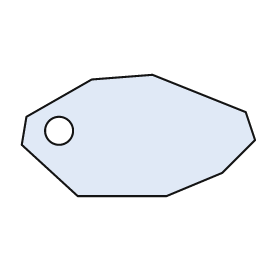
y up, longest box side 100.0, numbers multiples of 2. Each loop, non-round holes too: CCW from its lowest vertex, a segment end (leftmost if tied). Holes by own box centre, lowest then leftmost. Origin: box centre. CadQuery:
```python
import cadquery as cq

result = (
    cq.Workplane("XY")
    .moveTo(-26.0, -26.0)
    .lineTo(12.0, -26.0)
    .lineTo(36.0, -16.0)
    .lineTo(50.0, -2.0)
    .lineTo(46.0, 10.0)
    .lineTo(6.0, 26.0)
    .lineTo(-20.0, 24.0)
    .lineTo(-48.0, 8.0)
    .lineTo(-50.0, -4.0)
    .close()
    .moveTo(-34.0, 2.0)
    .circle(6.0)
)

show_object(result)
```